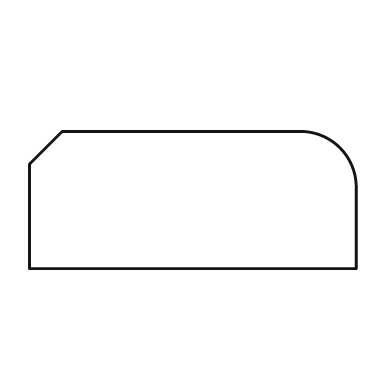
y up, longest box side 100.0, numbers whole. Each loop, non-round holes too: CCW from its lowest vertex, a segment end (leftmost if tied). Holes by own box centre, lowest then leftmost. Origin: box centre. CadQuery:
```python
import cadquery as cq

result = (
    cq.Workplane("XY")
    .moveTo(-50.0, -21.0)
    .lineTo(50.0, -21.0)
    .lineTo(50.0, 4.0)
    .threePointArc((45.0, 16.0), (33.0, 21.0))
    .lineTo(-40.0, 21.0)
    .lineTo(-50.0, 11.0)
    .close()
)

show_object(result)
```